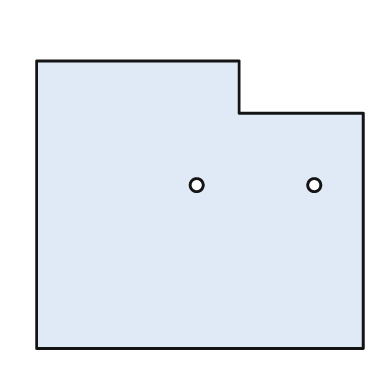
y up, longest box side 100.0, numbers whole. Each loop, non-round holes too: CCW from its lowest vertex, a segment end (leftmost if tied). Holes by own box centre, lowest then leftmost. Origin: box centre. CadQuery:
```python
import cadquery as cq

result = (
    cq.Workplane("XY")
    .moveTo(-50.0, -44.0)
    .lineTo(50.0, -44.0)
    .lineTo(50.0, 28.0)
    .lineTo(12.0, 28.0)
    .lineTo(12.0, 44.0)
    .lineTo(-50.0, 44.0)
    .close()
    .moveTo(-1.0, 6.0)
    .circle(2.0)
    .moveTo(35.0, 6.0)
    .circle(2.0)
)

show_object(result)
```